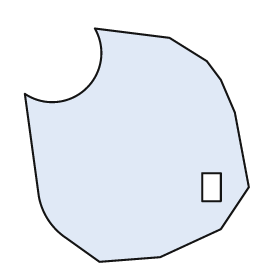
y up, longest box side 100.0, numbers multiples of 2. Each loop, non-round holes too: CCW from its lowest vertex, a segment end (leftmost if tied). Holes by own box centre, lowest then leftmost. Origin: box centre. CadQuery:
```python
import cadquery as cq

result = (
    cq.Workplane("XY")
    .moveTo(-16.0, -50.0)
    .lineTo(10.0, -48.0)
    .lineTo(36.0, -36.0)
    .lineTo(48.0, -18.0)
    .lineTo(42.0, 14.0)
    .lineTo(36.0, 28.0)
    .lineTo(30.0, 36.0)
    .lineTo(14.0, 46.0)
    .lineTo(-18.0, 50.0)
    .threePointArc((-22.0, 24.0), (-48.0, 22.0))
    .lineTo(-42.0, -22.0)
    .threePointArc((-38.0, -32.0), (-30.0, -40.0))
    .close()
    .moveTo(28.0, -24.0)
    .lineTo(36.0, -24.0)
    .lineTo(36.0, -12.0)
    .lineTo(28.0, -12.0)
    .close()
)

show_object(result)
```